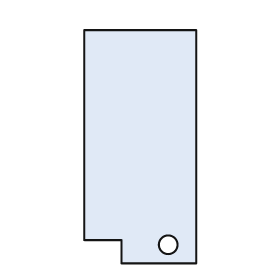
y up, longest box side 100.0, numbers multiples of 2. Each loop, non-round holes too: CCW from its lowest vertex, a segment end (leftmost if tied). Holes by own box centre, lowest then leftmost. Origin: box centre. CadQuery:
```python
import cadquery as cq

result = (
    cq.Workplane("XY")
    .moveTo(-8.0, -50.0)
    .lineTo(24.0, -50.0)
    .lineTo(24.0, 50.0)
    .lineTo(-24.0, 50.0)
    .lineTo(-24.0, -40.0)
    .lineTo(-8.0, -40.0)
    .close()
    .moveTo(12.0, -42.0)
    .circle(4.0)
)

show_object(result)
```